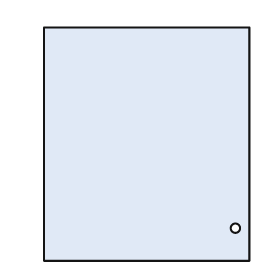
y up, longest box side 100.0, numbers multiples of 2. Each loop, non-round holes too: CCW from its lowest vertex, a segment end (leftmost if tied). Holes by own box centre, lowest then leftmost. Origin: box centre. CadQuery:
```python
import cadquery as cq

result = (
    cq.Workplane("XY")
    .moveTo(-44.0, -50.0)
    .lineTo(44.0, -50.0)
    .lineTo(44.0, 50.0)
    .lineTo(-44.0, 50.0)
    .close()
    .moveTo(38.0, -36.0)
    .circle(2.0)
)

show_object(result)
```